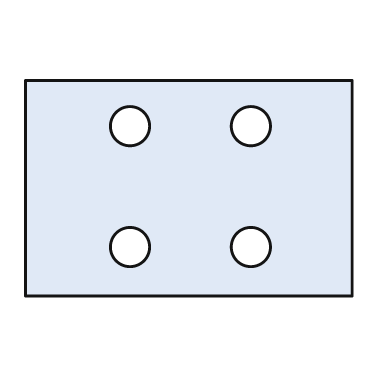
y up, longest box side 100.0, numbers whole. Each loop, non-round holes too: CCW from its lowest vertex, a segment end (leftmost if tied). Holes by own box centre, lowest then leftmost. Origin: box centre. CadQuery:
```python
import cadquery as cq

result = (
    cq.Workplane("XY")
    .moveTo(-50.0, -33.0)
    .lineTo(50.0, -33.0)
    .lineTo(50.0, 33.0)
    .lineTo(-50.0, 33.0)
    .close()
    .moveTo(-18.0, -18.0)
    .circle(6.0)
    .moveTo(19.0, -18.0)
    .circle(6.0)
    .moveTo(-18.0, 19.0)
    .circle(6.0)
    .moveTo(19.0, 19.0)
    .circle(6.0)
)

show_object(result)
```